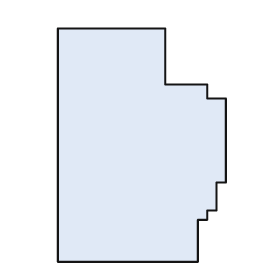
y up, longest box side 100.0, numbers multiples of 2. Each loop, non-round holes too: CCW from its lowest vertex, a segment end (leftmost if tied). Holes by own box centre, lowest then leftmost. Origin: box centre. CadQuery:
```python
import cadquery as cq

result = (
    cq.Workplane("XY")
    .moveTo(-36.0, -50.0)
    .lineTo(24.0, -50.0)
    .lineTo(24.0, -32.0)
    .lineTo(28.0, -32.0)
    .lineTo(28.0, -28.0)
    .lineTo(32.0, -28.0)
    .lineTo(32.0, -16.0)
    .lineTo(36.0, -16.0)
    .lineTo(36.0, 20.0)
    .lineTo(28.0, 20.0)
    .lineTo(28.0, 26.0)
    .lineTo(10.0, 26.0)
    .lineTo(10.0, 50.0)
    .lineTo(-36.0, 50.0)
    .close()
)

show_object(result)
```